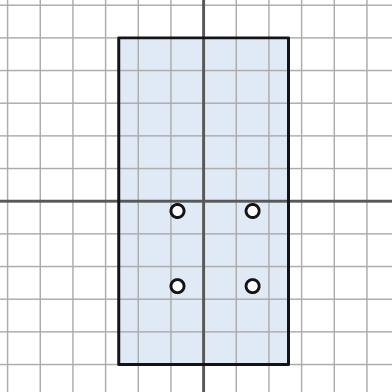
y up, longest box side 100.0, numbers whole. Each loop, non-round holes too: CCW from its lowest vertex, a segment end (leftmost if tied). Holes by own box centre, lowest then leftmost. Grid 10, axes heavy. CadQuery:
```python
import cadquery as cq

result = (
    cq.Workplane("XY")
    .moveTo(-26.0, -50.0)
    .lineTo(26.0, -50.0)
    .lineTo(26.0, 50.0)
    .lineTo(-26.0, 50.0)
    .close()
    .moveTo(-8.0, -26.0)
    .circle(2.0)
    .moveTo(15.0, -26.0)
    .circle(2.0)
    .moveTo(-8.0, -3.0)
    .circle(2.0)
    .moveTo(15.0, -3.0)
    .circle(2.0)
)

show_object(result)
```